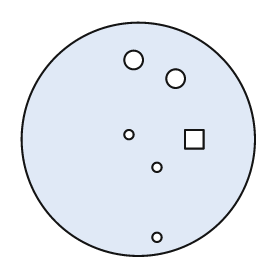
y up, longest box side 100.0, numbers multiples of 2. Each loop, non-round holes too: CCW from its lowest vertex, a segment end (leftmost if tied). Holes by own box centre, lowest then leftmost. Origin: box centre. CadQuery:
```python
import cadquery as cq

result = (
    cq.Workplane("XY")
    .moveTo(0.0, 0.0)
    .circle(50.0)
    .moveTo(8.0, -42.0)
    .circle(2.0)
    .moveTo(8.0, -12.0)
    .circle(2.0)
    .moveTo(20.0, -4.0)
    .lineTo(28.0, -4.0)
    .lineTo(28.0, 4.0)
    .lineTo(20.0, 4.0)
    .close()
    .moveTo(-4.0, 2.0)
    .circle(2.0)
    .moveTo(16.0, 26.0)
    .circle(4.0)
    .moveTo(-2.0, 34.0)
    .circle(4.0)
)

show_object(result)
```